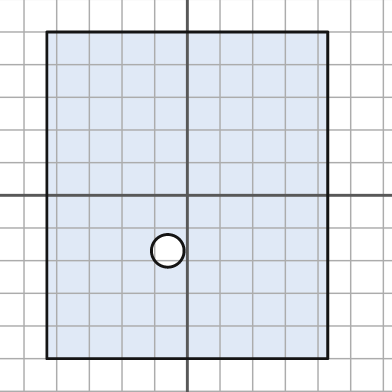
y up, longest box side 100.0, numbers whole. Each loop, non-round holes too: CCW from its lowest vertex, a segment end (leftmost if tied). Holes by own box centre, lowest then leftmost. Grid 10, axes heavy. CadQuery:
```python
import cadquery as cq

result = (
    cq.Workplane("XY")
    .moveTo(-43.0, -50.0)
    .lineTo(43.0, -50.0)
    .lineTo(43.0, 50.0)
    .lineTo(-43.0, 50.0)
    .close()
    .moveTo(-6.0, -17.0)
    .circle(5.0)
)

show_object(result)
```